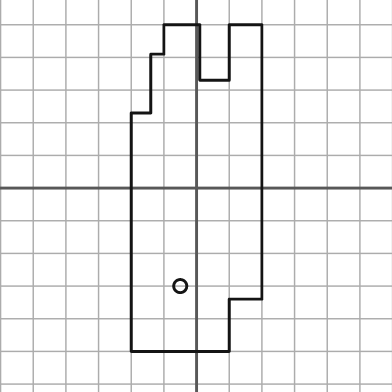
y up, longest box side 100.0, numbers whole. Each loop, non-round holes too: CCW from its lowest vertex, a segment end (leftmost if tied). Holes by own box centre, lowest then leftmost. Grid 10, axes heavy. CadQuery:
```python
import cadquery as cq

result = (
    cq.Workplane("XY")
    .moveTo(-20.0, -50.0)
    .lineTo(10.0, -50.0)
    .lineTo(10.0, -34.0)
    .lineTo(20.0, -34.0)
    .lineTo(20.0, 50.0)
    .lineTo(10.0, 50.0)
    .lineTo(10.0, 33.0)
    .lineTo(1.0, 33.0)
    .lineTo(1.0, 50.0)
    .lineTo(-10.0, 50.0)
    .lineTo(-10.0, 41.0)
    .lineTo(-14.0, 41.0)
    .lineTo(-14.0, 23.0)
    .lineTo(-20.0, 23.0)
    .close()
    .moveTo(-5.0, -30.0)
    .circle(2.0)
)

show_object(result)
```